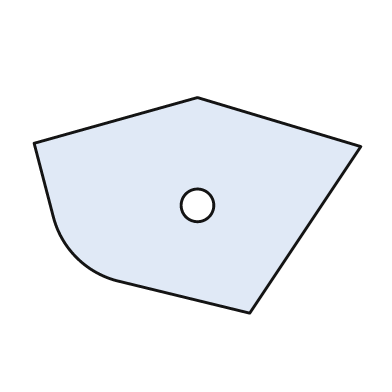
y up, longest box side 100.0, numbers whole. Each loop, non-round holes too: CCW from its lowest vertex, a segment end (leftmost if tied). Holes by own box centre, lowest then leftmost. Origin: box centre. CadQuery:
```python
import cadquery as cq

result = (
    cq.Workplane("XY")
    .moveTo(16.0, -33.0)
    .lineTo(50.0, 18.0)
    .lineTo(0.0, 33.0)
    .lineTo(-50.0, 19.0)
    .lineTo(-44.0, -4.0)
    .threePointArc((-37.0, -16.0), (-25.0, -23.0))
    .close()
    .moveTo(0.0, 0.0)
    .circle(5.0)
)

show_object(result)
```